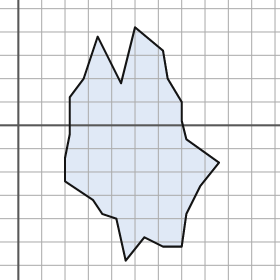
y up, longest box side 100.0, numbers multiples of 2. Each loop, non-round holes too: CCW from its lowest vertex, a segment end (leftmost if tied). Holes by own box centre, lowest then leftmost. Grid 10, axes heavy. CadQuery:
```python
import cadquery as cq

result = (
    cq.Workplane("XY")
    .moveTo(46.0, -58.0)
    .lineTo(54.0, -48.0)
    .lineTo(62.0, -52.0)
    .lineTo(70.0, -52.0)
    .lineTo(72.0, -38.0)
    .lineTo(78.0, -26.0)
    .lineTo(86.0, -16.0)
    .lineTo(72.0, -6.0)
    .lineTo(70.0, 2.0)
    .lineTo(70.0, 10.0)
    .lineTo(64.0, 20.0)
    .lineTo(62.0, 32.0)
    .lineTo(50.0, 42.0)
    .lineTo(44.0, 18.0)
    .lineTo(34.0, 38.0)
    .lineTo(28.0, 20.0)
    .lineTo(22.0, 12.0)
    .lineTo(22.0, -4.0)
    .lineTo(20.0, -14.0)
    .lineTo(20.0, -24.0)
    .lineTo(32.0, -32.0)
    .lineTo(36.0, -38.0)
    .lineTo(42.0, -40.0)
    .close()
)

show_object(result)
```